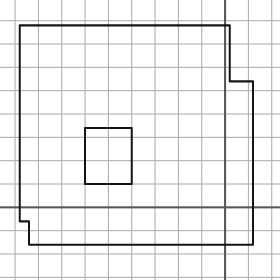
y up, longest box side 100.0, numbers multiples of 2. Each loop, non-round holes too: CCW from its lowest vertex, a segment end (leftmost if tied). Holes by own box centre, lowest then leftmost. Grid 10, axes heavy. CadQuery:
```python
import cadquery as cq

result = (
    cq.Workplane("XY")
    .moveTo(-84.0, -16.0)
    .lineTo(12.0, -16.0)
    .lineTo(12.0, 54.0)
    .lineTo(2.0, 54.0)
    .lineTo(2.0, 78.0)
    .lineTo(-88.0, 78.0)
    .lineTo(-88.0, -6.0)
    .lineTo(-84.0, -6.0)
    .close()
    .moveTo(-60.0, 10.0)
    .lineTo(-40.0, 10.0)
    .lineTo(-40.0, 34.0)
    .lineTo(-60.0, 34.0)
    .close()
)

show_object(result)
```